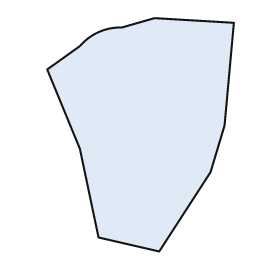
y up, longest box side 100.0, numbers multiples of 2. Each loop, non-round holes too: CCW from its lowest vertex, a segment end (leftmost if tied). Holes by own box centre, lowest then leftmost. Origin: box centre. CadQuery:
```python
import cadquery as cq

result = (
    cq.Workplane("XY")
    .moveTo(8.0, -50.0)
    .lineTo(30.0, -16.0)
    .lineTo(36.0, 4.0)
    .lineTo(40.0, 48.0)
    .lineTo(6.0, 50.0)
    .lineTo(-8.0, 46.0)
    .threePointArc((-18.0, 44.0), (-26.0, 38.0))
    .lineTo(-40.0, 28.0)
    .lineTo(-26.0, -6.0)
    .lineTo(-18.0, -44.0)
    .close()
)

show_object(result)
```